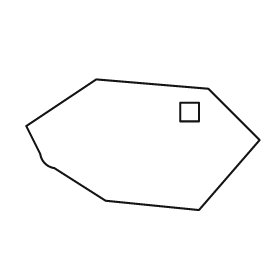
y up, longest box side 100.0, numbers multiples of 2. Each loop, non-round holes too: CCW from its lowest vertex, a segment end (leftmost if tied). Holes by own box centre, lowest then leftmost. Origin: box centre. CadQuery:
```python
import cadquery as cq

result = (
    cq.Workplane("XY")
    .moveTo(24.0, -28.0)
    .lineTo(50.0, 2.0)
    .lineTo(28.0, 24.0)
    .lineTo(-20.0, 28.0)
    .lineTo(-50.0, 8.0)
    .lineTo(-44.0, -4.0)
    .threePointArc((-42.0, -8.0), (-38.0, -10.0))
    .lineTo(-16.0, -24.0)
    .close()
    .moveTo(16.0, 10.0)
    .lineTo(24.0, 10.0)
    .lineTo(24.0, 18.0)
    .lineTo(16.0, 18.0)
    .close()
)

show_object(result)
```